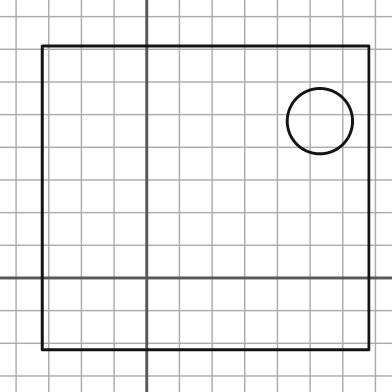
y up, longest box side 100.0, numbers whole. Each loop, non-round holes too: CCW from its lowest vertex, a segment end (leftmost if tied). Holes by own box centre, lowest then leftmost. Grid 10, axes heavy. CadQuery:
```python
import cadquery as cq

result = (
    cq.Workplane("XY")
    .moveTo(-32.0, -22.0)
    .lineTo(68.0, -22.0)
    .lineTo(68.0, 71.0)
    .lineTo(-32.0, 71.0)
    .close()
    .moveTo(53.0, 48.0)
    .circle(10.0)
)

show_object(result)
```